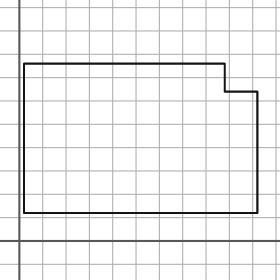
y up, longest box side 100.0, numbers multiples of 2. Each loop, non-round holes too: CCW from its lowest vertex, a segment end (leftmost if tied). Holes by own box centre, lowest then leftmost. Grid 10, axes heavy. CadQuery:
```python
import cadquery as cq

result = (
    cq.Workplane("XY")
    .moveTo(2.0, 12.0)
    .lineTo(102.0, 12.0)
    .lineTo(102.0, 64.0)
    .lineTo(88.0, 64.0)
    .lineTo(88.0, 76.0)
    .lineTo(2.0, 76.0)
    .close()
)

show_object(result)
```